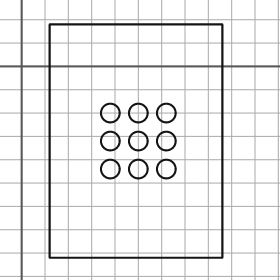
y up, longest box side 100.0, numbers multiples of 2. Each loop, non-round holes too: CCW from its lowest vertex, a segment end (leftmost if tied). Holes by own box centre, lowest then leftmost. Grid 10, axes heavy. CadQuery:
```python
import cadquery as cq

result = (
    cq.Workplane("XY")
    .moveTo(12.0, -82.0)
    .lineTo(86.0, -82.0)
    .lineTo(86.0, 18.0)
    .lineTo(12.0, 18.0)
    .close()
    .moveTo(38.0, -44.0)
    .circle(4.0)
    .moveTo(50.0, -44.0)
    .circle(4.0)
    .moveTo(62.0, -44.0)
    .circle(4.0)
    .moveTo(38.0, -32.0)
    .circle(4.0)
    .moveTo(50.0, -32.0)
    .circle(4.0)
    .moveTo(62.0, -32.0)
    .circle(4.0)
    .moveTo(38.0, -20.0)
    .circle(4.0)
    .moveTo(50.0, -20.0)
    .circle(4.0)
    .moveTo(62.0, -20.0)
    .circle(4.0)
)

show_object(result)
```